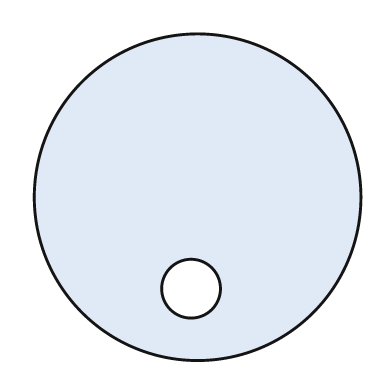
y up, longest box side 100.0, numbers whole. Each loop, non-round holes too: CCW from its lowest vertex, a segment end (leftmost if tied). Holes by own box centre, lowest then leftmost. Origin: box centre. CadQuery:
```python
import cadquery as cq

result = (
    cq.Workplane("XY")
    .moveTo(0.0, 0.0)
    .circle(50.0)
    .moveTo(-2.0, -28.0)
    .circle(9.0)
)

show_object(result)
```